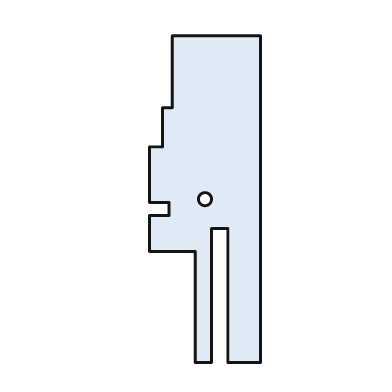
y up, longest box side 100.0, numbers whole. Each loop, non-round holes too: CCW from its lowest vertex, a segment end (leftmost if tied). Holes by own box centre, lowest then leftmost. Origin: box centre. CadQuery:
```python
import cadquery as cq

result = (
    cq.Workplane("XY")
    .moveTo(-3.0, -50.0)
    .lineTo(2.0, -50.0)
    .lineTo(2.0, -9.0)
    .lineTo(7.0, -9.0)
    .lineTo(7.0, -50.0)
    .lineTo(17.0, -50.0)
    .lineTo(17.0, 50.0)
    .lineTo(-10.0, 50.0)
    .lineTo(-10.0, 28.0)
    .lineTo(-13.0, 28.0)
    .lineTo(-13.0, 16.0)
    .lineTo(-17.0, 16.0)
    .lineTo(-17.0, -1.0)
    .lineTo(-11.0, -1.0)
    .lineTo(-11.0, -5.0)
    .lineTo(-17.0, -5.0)
    .lineTo(-17.0, -16.0)
    .lineTo(-3.0, -16.0)
    .close()
    .moveTo(0.0, 0.0)
    .circle(2.0)
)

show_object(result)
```